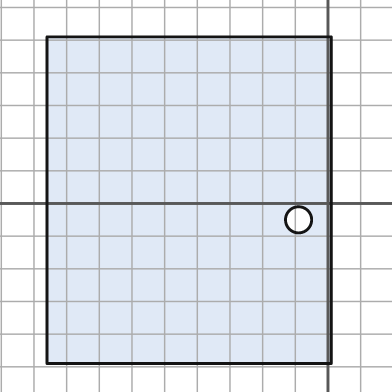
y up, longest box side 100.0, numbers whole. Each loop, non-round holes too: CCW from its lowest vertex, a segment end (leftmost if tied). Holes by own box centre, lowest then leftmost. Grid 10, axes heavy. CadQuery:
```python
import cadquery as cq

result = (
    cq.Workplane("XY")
    .moveTo(-86.0, -49.0)
    .lineTo(1.0, -49.0)
    .lineTo(1.0, 51.0)
    .lineTo(-86.0, 51.0)
    .close()
    .moveTo(-9.0, -5.0)
    .circle(4.0)
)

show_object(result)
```